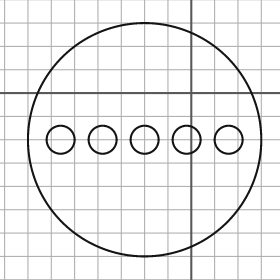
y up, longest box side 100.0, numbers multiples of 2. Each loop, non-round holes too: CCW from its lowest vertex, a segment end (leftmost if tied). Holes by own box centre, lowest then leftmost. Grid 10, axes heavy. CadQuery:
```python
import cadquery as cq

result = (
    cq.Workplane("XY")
    .moveTo(-20.0, -20.0)
    .circle(50.0)
    .moveTo(-56.0, -20.0)
    .circle(6.0)
    .moveTo(-38.0, -20.0)
    .circle(6.0)
    .moveTo(-20.0, -20.0)
    .circle(6.0)
    .moveTo(-2.0, -20.0)
    .circle(6.0)
    .moveTo(16.0, -20.0)
    .circle(6.0)
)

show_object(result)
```